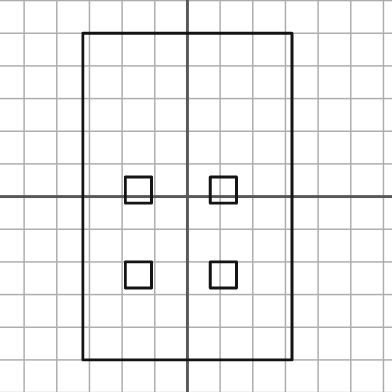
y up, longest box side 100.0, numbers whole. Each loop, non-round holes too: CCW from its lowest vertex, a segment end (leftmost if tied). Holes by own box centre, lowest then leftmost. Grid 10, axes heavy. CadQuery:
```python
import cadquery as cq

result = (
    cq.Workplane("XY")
    .moveTo(-32.0, -50.0)
    .lineTo(32.0, -50.0)
    .lineTo(32.0, 50.0)
    .lineTo(-32.0, 50.0)
    .close()
    .moveTo(-19.0, -28.0)
    .lineTo(-11.0, -28.0)
    .lineTo(-11.0, -20.0)
    .lineTo(-19.0, -20.0)
    .close()
    .moveTo(7.0, -28.0)
    .lineTo(15.0, -28.0)
    .lineTo(15.0, -20.0)
    .lineTo(7.0, -20.0)
    .close()
    .moveTo(-19.0, -2.0)
    .lineTo(-11.0, -2.0)
    .lineTo(-11.0, 6.0)
    .lineTo(-19.0, 6.0)
    .close()
    .moveTo(7.0, -2.0)
    .lineTo(15.0, -2.0)
    .lineTo(15.0, 6.0)
    .lineTo(7.0, 6.0)
    .close()
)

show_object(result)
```